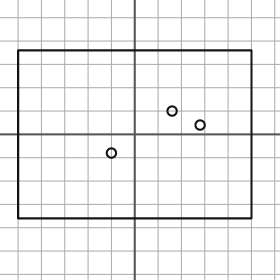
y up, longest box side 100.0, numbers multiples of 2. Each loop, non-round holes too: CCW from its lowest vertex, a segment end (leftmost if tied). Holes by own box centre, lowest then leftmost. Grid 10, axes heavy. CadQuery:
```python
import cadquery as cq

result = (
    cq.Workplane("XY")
    .moveTo(-50.0, -36.0)
    .lineTo(50.0, -36.0)
    .lineTo(50.0, 36.0)
    .lineTo(-50.0, 36.0)
    .close()
    .moveTo(-10.0, -8.0)
    .circle(2.0)
    .moveTo(28.0, 4.0)
    .circle(2.0)
    .moveTo(16.0, 10.0)
    .circle(2.0)
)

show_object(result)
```